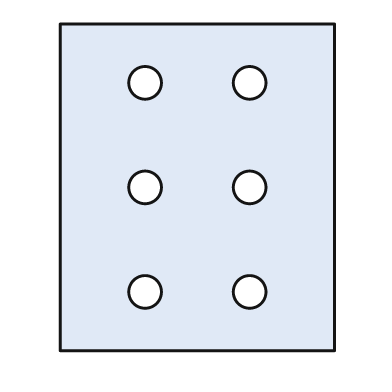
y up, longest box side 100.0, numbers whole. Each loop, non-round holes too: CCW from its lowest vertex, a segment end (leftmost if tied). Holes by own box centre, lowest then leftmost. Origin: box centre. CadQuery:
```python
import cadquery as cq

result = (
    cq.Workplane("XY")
    .moveTo(-42.0, -50.0)
    .lineTo(42.0, -50.0)
    .lineTo(42.0, 50.0)
    .lineTo(-42.0, 50.0)
    .close()
    .moveTo(-16.0, -32.0)
    .circle(5.0)
    .moveTo(16.0, -32.0)
    .circle(5.0)
    .moveTo(-16.0, 0.0)
    .circle(5.0)
    .moveTo(16.0, 0.0)
    .circle(5.0)
    .moveTo(-16.0, 32.0)
    .circle(5.0)
    .moveTo(16.0, 32.0)
    .circle(5.0)
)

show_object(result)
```